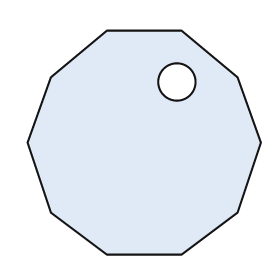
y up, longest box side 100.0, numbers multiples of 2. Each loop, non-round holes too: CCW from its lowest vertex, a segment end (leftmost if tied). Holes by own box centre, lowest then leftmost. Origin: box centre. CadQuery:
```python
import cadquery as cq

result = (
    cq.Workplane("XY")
    .moveTo(-16.0, -48.0)
    .lineTo(16.0, -48.0)
    .lineTo(40.0, -30.0)
    .lineTo(50.0, 0.0)
    .lineTo(40.0, 28.0)
    .lineTo(16.0, 48.0)
    .lineTo(-16.0, 48.0)
    .lineTo(-40.0, 28.0)
    .lineTo(-50.0, 0.0)
    .lineTo(-40.0, -30.0)
    .close()
    .moveTo(14.0, 26.0)
    .circle(8.0)
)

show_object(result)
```